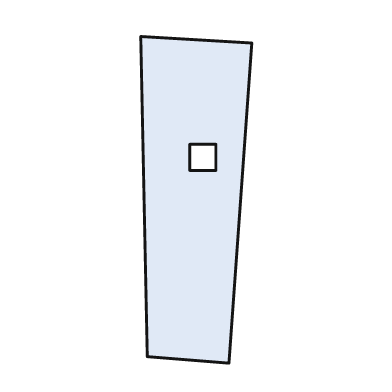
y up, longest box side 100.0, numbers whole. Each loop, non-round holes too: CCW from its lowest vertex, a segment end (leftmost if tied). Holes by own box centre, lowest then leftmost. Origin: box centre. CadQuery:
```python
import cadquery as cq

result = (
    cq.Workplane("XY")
    .moveTo(10.0, -50.0)
    .lineTo(17.0, 48.0)
    .lineTo(-17.0, 50.0)
    .lineTo(-15.0, -48.0)
    .close()
    .moveTo(-2.0, 9.0)
    .lineTo(6.0, 9.0)
    .lineTo(6.0, 17.0)
    .lineTo(-2.0, 17.0)
    .close()
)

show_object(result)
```